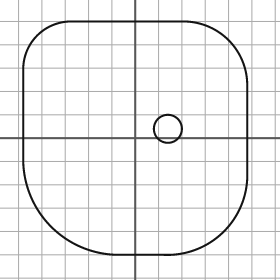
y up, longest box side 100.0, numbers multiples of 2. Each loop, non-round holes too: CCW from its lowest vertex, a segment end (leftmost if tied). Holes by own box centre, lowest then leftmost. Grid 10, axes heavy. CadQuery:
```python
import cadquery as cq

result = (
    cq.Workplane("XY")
    .moveTo(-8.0, -50.0)
    .lineTo(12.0, -50.0)
    .threePointArc((38.0, -40.0), (48.0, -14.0))
    .lineTo(48.0, 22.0)
    .threePointArc((40.0, 42.0), (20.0, 50.0))
    .lineTo(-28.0, 50.0)
    .threePointArc((-42.0, 44.0), (-48.0, 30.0))
    .lineTo(-48.0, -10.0)
    .threePointArc((-36.0, -38.0), (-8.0, -50.0))
    .close()
    .moveTo(14.0, 4.0)
    .circle(6.0)
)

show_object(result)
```